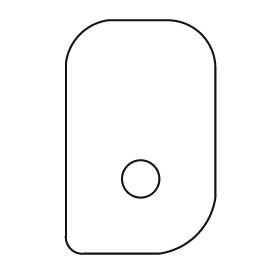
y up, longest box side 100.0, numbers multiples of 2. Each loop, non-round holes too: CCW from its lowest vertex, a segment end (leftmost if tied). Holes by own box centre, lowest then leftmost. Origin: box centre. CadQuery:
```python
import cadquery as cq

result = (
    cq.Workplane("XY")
    .moveTo(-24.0, -50.0)
    .lineTo(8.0, -50.0)
    .threePointArc((24.0, -42.0), (32.0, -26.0))
    .lineTo(32.0, 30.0)
    .threePointArc((26.0, 44.0), (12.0, 50.0))
    .lineTo(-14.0, 50.0)
    .threePointArc((-26.0, 44.0), (-32.0, 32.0))
    .lineTo(-32.0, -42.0)
    .threePointArc((-30.0, -48.0), (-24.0, -50.0))
    .close()
    .moveTo(0.0, -18.0)
    .circle(8.0)
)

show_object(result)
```